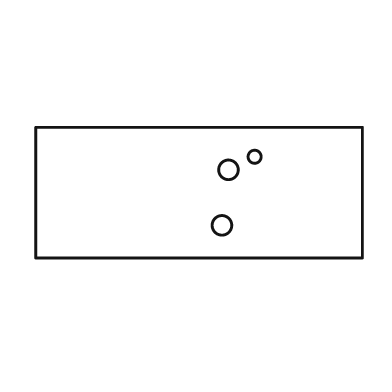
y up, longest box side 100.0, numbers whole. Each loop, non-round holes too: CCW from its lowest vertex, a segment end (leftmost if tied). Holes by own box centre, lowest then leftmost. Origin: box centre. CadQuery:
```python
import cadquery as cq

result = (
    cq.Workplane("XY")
    .moveTo(-50.0, -20.0)
    .lineTo(50.0, -20.0)
    .lineTo(50.0, 20.0)
    .lineTo(-50.0, 20.0)
    .close()
    .moveTo(7.0, -10.0)
    .circle(3.0)
    .moveTo(9.0, 7.0)
    .circle(3.0)
    .moveTo(17.0, 11.0)
    .circle(2.0)
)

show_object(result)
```